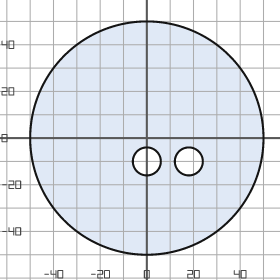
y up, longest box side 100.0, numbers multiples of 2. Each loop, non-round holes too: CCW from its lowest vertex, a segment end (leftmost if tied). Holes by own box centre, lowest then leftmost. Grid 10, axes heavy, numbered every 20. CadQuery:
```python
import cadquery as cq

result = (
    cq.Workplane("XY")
    .moveTo(0.0, 0.0)
    .circle(50.0)
    .moveTo(0.0, -10.0)
    .circle(6.0)
    .moveTo(18.0, -10.0)
    .circle(6.0)
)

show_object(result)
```